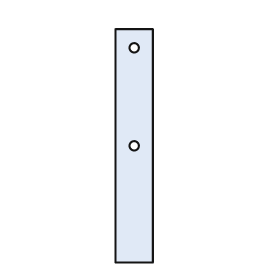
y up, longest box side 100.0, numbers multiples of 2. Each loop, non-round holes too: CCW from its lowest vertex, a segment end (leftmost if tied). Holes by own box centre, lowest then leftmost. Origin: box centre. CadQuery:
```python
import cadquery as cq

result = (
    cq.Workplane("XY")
    .moveTo(-8.0, -50.0)
    .lineTo(8.0, -50.0)
    .lineTo(8.0, 50.0)
    .lineTo(-8.0, 50.0)
    .close()
    .moveTo(0.0, 0.0)
    .circle(2.0)
    .moveTo(0.0, 42.0)
    .circle(2.0)
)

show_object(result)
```